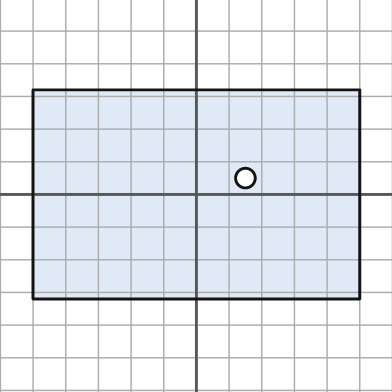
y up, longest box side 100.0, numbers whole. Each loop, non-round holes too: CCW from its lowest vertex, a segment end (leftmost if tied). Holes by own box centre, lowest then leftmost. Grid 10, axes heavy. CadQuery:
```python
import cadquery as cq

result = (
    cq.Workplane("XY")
    .moveTo(-50.0, -32.0)
    .lineTo(50.0, -32.0)
    .lineTo(50.0, 32.0)
    .lineTo(-50.0, 32.0)
    .close()
    .moveTo(15.0, 5.0)
    .circle(3.0)
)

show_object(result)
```